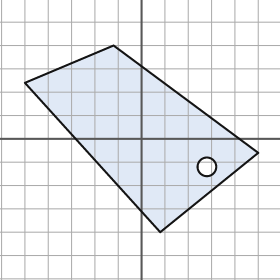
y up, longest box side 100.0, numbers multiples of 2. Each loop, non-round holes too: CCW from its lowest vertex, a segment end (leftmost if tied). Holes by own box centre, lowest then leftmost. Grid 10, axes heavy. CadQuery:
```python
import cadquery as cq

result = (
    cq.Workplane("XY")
    .moveTo(8.0, -40.0)
    .lineTo(50.0, -6.0)
    .lineTo(-12.0, 40.0)
    .lineTo(-50.0, 24.0)
    .close()
    .moveTo(28.0, -12.0)
    .circle(4.0)
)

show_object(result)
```